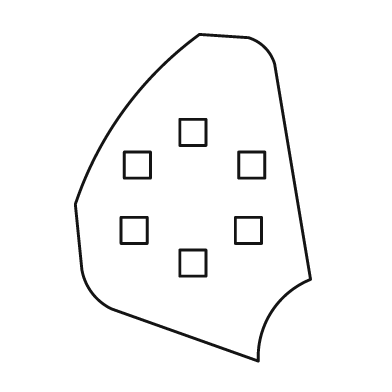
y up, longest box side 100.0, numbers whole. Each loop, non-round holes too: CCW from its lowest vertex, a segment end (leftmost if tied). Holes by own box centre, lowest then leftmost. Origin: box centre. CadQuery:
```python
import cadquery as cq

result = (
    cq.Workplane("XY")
    .moveTo(20.0, -50.0)
    .threePointArc((24.0, -35.0), (36.0, -25.0))
    .lineTo(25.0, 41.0)
    .threePointArc((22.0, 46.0), (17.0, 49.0))
    .lineTo(2.0, 50.0)
    .threePointArc((-21.0, 27.0), (-36.0, -2.0))
    .lineTo(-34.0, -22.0)
    .threePointArc((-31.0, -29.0), (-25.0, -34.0))
    .close()
    .moveTo(-4.0, -24.0)
    .lineTo(4.0, -24.0)
    .lineTo(4.0, -16.0)
    .lineTo(-4.0, -16.0)
    .close()
    .moveTo(-22.0, -14.0)
    .lineTo(-14.0, -14.0)
    .lineTo(-14.0, -6.0)
    .lineTo(-22.0, -6.0)
    .close()
    .moveTo(13.0, -14.0)
    .lineTo(21.0, -14.0)
    .lineTo(21.0, -6.0)
    .lineTo(13.0, -6.0)
    .close()
    .moveTo(-21.0, 6.0)
    .lineTo(-13.0, 6.0)
    .lineTo(-13.0, 14.0)
    .lineTo(-21.0, 14.0)
    .close()
    .moveTo(14.0, 6.0)
    .lineTo(22.0, 6.0)
    .lineTo(22.0, 14.0)
    .lineTo(14.0, 14.0)
    .close()
    .moveTo(-4.0, 16.0)
    .lineTo(4.0, 16.0)
    .lineTo(4.0, 24.0)
    .lineTo(-4.0, 24.0)
    .close()
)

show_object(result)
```